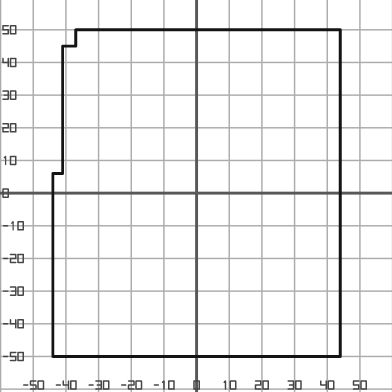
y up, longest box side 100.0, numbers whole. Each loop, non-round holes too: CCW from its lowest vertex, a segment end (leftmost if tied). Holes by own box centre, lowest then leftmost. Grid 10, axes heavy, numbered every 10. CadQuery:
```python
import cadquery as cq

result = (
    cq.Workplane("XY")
    .moveTo(-44.0, -50.0)
    .lineTo(44.0, -50.0)
    .lineTo(44.0, 50.0)
    .lineTo(-37.0, 50.0)
    .lineTo(-37.0, 45.0)
    .lineTo(-41.0, 45.0)
    .lineTo(-41.0, 6.0)
    .lineTo(-44.0, 6.0)
    .close()
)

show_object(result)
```